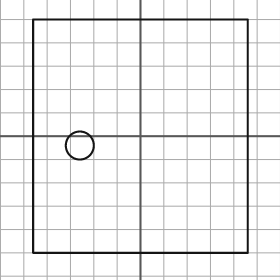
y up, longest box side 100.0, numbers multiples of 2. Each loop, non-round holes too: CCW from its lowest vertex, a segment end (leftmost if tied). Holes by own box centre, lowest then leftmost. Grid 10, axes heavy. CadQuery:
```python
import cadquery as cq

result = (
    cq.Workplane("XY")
    .moveTo(-46.0, -50.0)
    .lineTo(46.0, -50.0)
    .lineTo(46.0, 50.0)
    .lineTo(-46.0, 50.0)
    .close()
    .moveTo(-26.0, -4.0)
    .circle(6.0)
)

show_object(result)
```